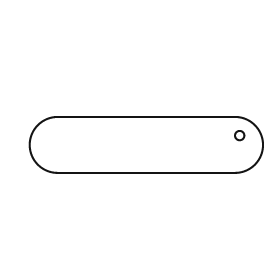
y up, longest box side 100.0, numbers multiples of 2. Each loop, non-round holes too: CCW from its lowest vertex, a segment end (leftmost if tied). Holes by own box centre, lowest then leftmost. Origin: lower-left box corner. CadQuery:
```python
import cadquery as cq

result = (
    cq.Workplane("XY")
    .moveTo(12.0, 0.0)
    .lineTo(88.0, 0.0)
    .threePointArc((100.0, 12.0), (88.0, 24.0))
    .lineTo(12.0, 24.0)
    .threePointArc((0.0, 12.0), (12.0, 0.0))
    .close()
    .moveTo(90.0, 16.0)
    .circle(2.0)
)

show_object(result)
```